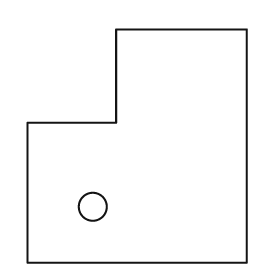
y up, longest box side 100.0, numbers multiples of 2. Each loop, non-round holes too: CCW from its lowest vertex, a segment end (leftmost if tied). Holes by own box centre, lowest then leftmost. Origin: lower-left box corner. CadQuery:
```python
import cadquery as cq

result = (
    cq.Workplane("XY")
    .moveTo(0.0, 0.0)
    .lineTo(94.0, 0.0)
    .lineTo(94.0, 100.0)
    .lineTo(38.0, 100.0)
    .lineTo(38.0, 60.0)
    .lineTo(0.0, 60.0)
    .close()
    .moveTo(28.0, 24.0)
    .circle(6.0)
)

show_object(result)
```